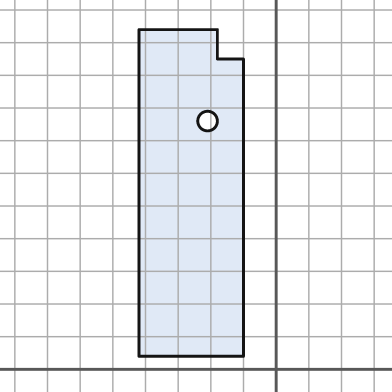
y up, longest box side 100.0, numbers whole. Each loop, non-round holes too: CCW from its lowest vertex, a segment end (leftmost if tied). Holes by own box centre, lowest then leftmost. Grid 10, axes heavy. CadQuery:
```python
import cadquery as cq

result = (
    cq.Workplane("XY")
    .moveTo(-42.0, 4.0)
    .lineTo(-10.0, 4.0)
    .lineTo(-10.0, 95.0)
    .lineTo(-18.0, 95.0)
    .lineTo(-18.0, 104.0)
    .lineTo(-42.0, 104.0)
    .close()
    .moveTo(-21.0, 76.0)
    .circle(3.0)
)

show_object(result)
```